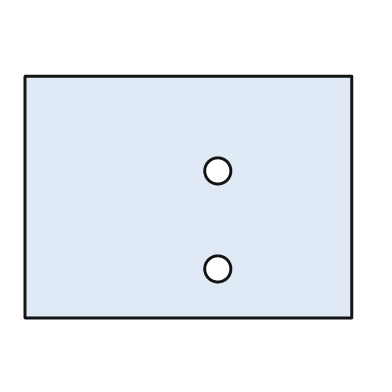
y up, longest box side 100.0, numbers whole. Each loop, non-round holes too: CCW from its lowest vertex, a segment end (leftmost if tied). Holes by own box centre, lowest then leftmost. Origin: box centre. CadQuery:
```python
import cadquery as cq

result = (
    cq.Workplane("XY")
    .moveTo(-50.0, -37.0)
    .lineTo(50.0, -37.0)
    .lineTo(50.0, 37.0)
    .lineTo(-50.0, 37.0)
    .close()
    .moveTo(9.0, -22.0)
    .circle(4.0)
    .moveTo(9.0, 8.0)
    .circle(4.0)
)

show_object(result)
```